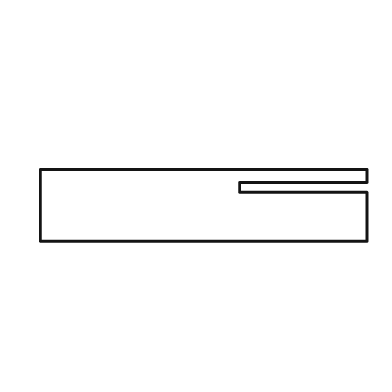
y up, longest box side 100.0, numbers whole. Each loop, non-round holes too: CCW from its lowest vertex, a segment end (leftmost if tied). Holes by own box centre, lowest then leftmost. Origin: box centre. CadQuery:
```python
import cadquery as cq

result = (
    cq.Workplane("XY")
    .moveTo(-50.0, -11.0)
    .lineTo(50.0, -11.0)
    .lineTo(50.0, 4.0)
    .lineTo(11.0, 4.0)
    .lineTo(11.0, 7.0)
    .lineTo(50.0, 7.0)
    .lineTo(50.0, 11.0)
    .lineTo(-50.0, 11.0)
    .close()
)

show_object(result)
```